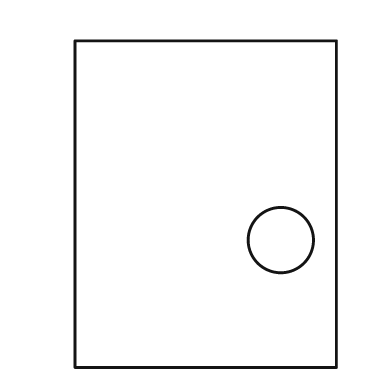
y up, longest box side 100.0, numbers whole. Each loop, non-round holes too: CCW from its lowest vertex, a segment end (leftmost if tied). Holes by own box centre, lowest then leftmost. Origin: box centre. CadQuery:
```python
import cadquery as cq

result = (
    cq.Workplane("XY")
    .moveTo(-40.0, -50.0)
    .lineTo(40.0, -50.0)
    .lineTo(40.0, 50.0)
    .lineTo(-40.0, 50.0)
    .close()
    .moveTo(23.0, -11.0)
    .circle(10.0)
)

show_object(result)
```